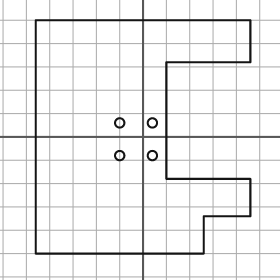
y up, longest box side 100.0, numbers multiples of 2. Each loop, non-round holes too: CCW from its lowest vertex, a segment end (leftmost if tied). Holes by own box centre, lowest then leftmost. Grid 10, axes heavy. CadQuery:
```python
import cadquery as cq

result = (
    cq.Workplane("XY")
    .moveTo(-46.0, -50.0)
    .lineTo(26.0, -50.0)
    .lineTo(26.0, -34.0)
    .lineTo(46.0, -34.0)
    .lineTo(46.0, -18.0)
    .lineTo(10.0, -18.0)
    .lineTo(10.0, 32.0)
    .lineTo(46.0, 32.0)
    .lineTo(46.0, 50.0)
    .lineTo(-46.0, 50.0)
    .close()
    .moveTo(-10.0, -8.0)
    .circle(2.0)
    .moveTo(4.0, -8.0)
    .circle(2.0)
    .moveTo(-10.0, 6.0)
    .circle(2.0)
    .moveTo(4.0, 6.0)
    .circle(2.0)
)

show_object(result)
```